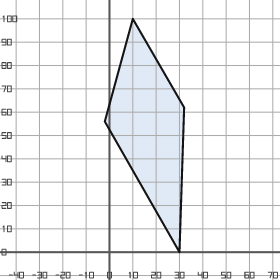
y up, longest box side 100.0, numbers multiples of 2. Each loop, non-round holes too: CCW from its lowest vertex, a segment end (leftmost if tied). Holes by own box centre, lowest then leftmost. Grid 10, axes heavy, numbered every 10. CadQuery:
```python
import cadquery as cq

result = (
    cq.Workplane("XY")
    .moveTo(30.0, 0.0)
    .lineTo(32.0, 62.0)
    .lineTo(10.0, 100.0)
    .lineTo(-2.0, 56.0)
    .close()
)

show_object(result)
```